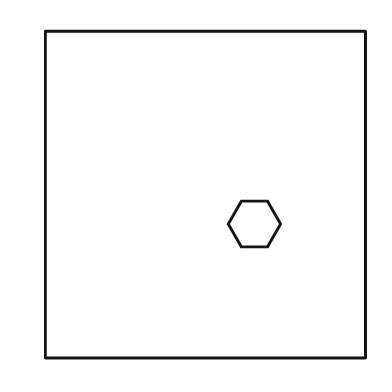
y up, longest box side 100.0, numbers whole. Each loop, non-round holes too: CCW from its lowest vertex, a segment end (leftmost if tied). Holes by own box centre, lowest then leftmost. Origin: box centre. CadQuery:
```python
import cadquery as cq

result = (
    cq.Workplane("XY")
    .moveTo(-49.0, -50.0)
    .lineTo(49.0, -50.0)
    .lineTo(49.0, 50.0)
    .lineTo(-49.0, 50.0)
    .close()
    .moveTo(11.0, -16.0)
    .lineTo(19.0, -16.0)
    .lineTo(23.0, -9.0)
    .lineTo(19.0, -2.0)
    .lineTo(11.0, -2.0)
    .lineTo(7.0, -9.0)
    .close()
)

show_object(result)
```